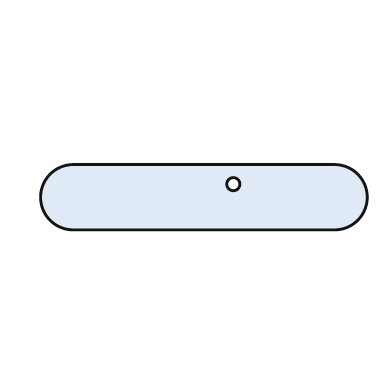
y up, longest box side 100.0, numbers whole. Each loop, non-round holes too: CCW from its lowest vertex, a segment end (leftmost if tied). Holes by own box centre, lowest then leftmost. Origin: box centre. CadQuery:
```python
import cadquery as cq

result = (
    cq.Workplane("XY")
    .moveTo(-40.0, -10.0)
    .lineTo(40.0, -10.0)
    .threePointArc((50.0, 0.0), (40.0, 10.0))
    .lineTo(-40.0, 10.0)
    .threePointArc((-50.0, 0.0), (-40.0, -10.0))
    .close()
    .moveTo(9.0, 4.0)
    .circle(2.0)
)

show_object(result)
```